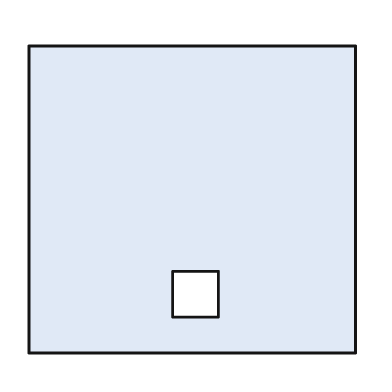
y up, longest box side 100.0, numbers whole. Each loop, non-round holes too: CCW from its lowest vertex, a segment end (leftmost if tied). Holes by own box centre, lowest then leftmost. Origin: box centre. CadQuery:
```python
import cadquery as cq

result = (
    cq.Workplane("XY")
    .moveTo(-50.0, -47.0)
    .lineTo(50.0, -47.0)
    .lineTo(50.0, 47.0)
    .lineTo(-50.0, 47.0)
    .close()
    .moveTo(-6.0, -36.0)
    .lineTo(8.0, -36.0)
    .lineTo(8.0, -22.0)
    .lineTo(-6.0, -22.0)
    .close()
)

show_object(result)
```